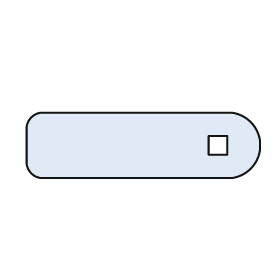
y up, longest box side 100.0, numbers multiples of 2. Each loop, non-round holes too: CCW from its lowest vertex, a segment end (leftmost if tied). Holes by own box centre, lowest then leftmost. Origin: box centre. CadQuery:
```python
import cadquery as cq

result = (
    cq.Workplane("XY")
    .moveTo(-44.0, -14.0)
    .lineTo(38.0, -14.0)
    .threePointArc((46.0, -10.0), (50.0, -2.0))
    .lineTo(50.0, 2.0)
    .threePointArc((46.0, 10.0), (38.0, 14.0))
    .lineTo(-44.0, 14.0)
    .threePointArc((-48.0, 12.0), (-50.0, 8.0))
    .lineTo(-50.0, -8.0)
    .threePointArc((-48.0, -12.0), (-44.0, -14.0))
    .close()
    .moveTo(28.0, -4.0)
    .lineTo(36.0, -4.0)
    .lineTo(36.0, 4.0)
    .lineTo(28.0, 4.0)
    .close()
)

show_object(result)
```